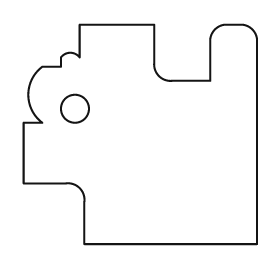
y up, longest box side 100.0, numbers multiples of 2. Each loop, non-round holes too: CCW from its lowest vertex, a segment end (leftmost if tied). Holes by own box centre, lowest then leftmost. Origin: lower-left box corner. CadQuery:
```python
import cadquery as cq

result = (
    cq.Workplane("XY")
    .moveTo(26.0, 0.0)
    .lineTo(100.0, 0.0)
    .lineTo(100.0, 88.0)
    .threePointArc((98.0, 92.0), (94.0, 94.0))
    .lineTo(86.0, 94.0)
    .threePointArc((82.0, 92.0), (80.0, 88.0))
    .lineTo(80.0, 70.0)
    .lineTo(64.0, 70.0)
    .threePointArc((58.0, 72.0), (56.0, 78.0))
    .lineTo(56.0, 94.0)
    .lineTo(24.0, 94.0)
    .lineTo(24.0, 80.0)
    .threePointArc((20.0, 82.0), (16.0, 80.0))
    .lineTo(16.0, 76.0)
    .lineTo(8.0, 76.0)
    .threePointArc((2.0, 64.0), (8.0, 52.0))
    .lineTo(0.0, 52.0)
    .lineTo(0.0, 26.0)
    .lineTo(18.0, 26.0)
    .threePointArc((24.0, 24.0), (26.0, 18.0))
    .close()
    .moveTo(22.0, 58.0)
    .circle(6.0)
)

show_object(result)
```